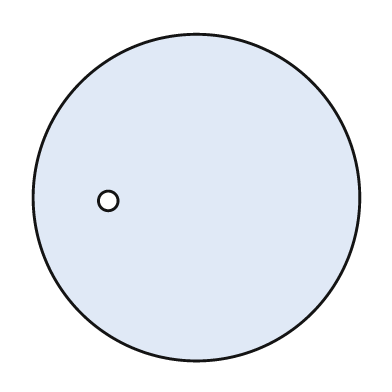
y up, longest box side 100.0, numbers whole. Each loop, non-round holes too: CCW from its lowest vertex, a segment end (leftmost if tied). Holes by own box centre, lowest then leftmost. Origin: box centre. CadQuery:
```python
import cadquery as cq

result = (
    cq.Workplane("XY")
    .moveTo(0.0, 0.0)
    .circle(50.0)
    .moveTo(-27.0, -1.0)
    .circle(3.0)
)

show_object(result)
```